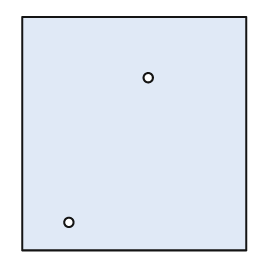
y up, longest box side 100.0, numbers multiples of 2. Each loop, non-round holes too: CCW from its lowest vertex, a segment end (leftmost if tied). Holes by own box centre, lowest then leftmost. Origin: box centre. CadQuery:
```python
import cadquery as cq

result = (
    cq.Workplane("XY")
    .moveTo(-48.0, -50.0)
    .lineTo(48.0, -50.0)
    .lineTo(48.0, 50.0)
    .lineTo(-48.0, 50.0)
    .close()
    .moveTo(-28.0, -38.0)
    .circle(2.0)
    .moveTo(6.0, 24.0)
    .circle(2.0)
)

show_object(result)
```